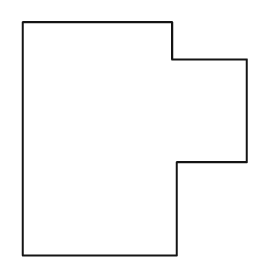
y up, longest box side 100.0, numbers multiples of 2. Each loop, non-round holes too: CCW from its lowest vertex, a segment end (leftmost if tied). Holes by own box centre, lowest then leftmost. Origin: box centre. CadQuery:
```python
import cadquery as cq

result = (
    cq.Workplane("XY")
    .moveTo(-48.0, -50.0)
    .lineTo(18.0, -50.0)
    .lineTo(18.0, -10.0)
    .lineTo(48.0, -10.0)
    .lineTo(48.0, 34.0)
    .lineTo(16.0, 34.0)
    .lineTo(16.0, 50.0)
    .lineTo(-48.0, 50.0)
    .close()
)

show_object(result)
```